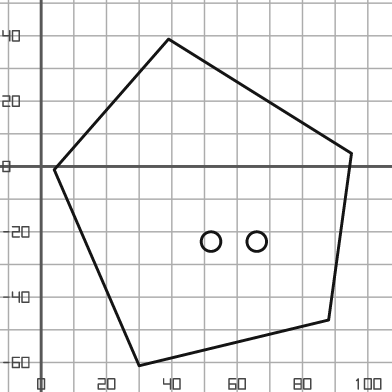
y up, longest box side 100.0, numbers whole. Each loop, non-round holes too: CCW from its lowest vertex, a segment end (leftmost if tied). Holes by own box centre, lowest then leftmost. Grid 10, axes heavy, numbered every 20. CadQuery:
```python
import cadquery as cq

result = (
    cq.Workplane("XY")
    .moveTo(30.0, -61.0)
    .lineTo(88.0, -47.0)
    .lineTo(95.0, 4.0)
    .lineTo(39.0, 39.0)
    .lineTo(4.0, -1.0)
    .close()
    .moveTo(52.0, -23.0)
    .circle(3.0)
    .moveTo(66.0, -23.0)
    .circle(3.0)
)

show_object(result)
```